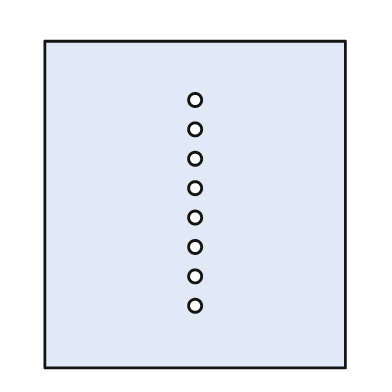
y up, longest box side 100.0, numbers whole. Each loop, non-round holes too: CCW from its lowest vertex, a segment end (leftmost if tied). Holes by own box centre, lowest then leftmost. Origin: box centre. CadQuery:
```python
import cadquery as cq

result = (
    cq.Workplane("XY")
    .moveTo(-46.0, -50.0)
    .lineTo(46.0, -50.0)
    .lineTo(46.0, 50.0)
    .lineTo(-46.0, 50.0)
    .close()
    .moveTo(0.0, -31.0)
    .circle(2.0)
    .moveTo(0.0, -22.0)
    .circle(2.0)
    .moveTo(0.0, -13.0)
    .circle(2.0)
    .moveTo(0.0, -4.0)
    .circle(2.0)
    .moveTo(0.0, 5.0)
    .circle(2.0)
    .moveTo(0.0, 14.0)
    .circle(2.0)
    .moveTo(0.0, 23.0)
    .circle(2.0)
    .moveTo(0.0, 32.0)
    .circle(2.0)
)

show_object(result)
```